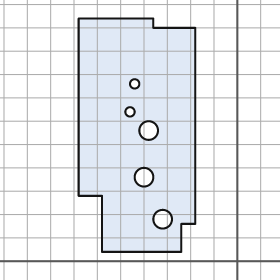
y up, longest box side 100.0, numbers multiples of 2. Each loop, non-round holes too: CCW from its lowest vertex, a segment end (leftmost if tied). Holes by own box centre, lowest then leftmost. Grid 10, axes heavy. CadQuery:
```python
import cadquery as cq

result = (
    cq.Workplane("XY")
    .moveTo(-58.0, 4.0)
    .lineTo(-24.0, 4.0)
    .lineTo(-24.0, 16.0)
    .lineTo(-18.0, 16.0)
    .lineTo(-18.0, 100.0)
    .lineTo(-36.0, 100.0)
    .lineTo(-36.0, 104.0)
    .lineTo(-68.0, 104.0)
    .lineTo(-68.0, 28.0)
    .lineTo(-58.0, 28.0)
    .close()
    .moveTo(-32.0, 18.0)
    .circle(4.0)
    .moveTo(-40.0, 36.0)
    .circle(4.0)
    .moveTo(-38.0, 56.0)
    .circle(4.0)
    .moveTo(-46.0, 64.0)
    .circle(2.0)
    .moveTo(-44.0, 76.0)
    .circle(2.0)
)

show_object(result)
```